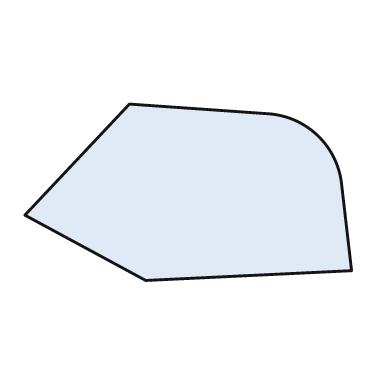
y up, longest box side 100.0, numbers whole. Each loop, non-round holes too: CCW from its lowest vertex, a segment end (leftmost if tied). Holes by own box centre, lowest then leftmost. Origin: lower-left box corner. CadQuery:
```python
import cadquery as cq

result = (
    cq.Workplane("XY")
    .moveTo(37.0, 0.0)
    .lineTo(100.0, 3.0)
    .lineTo(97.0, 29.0)
    .threePointArc((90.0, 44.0), (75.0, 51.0))
    .lineTo(32.0, 54.0)
    .lineTo(0.0, 20.0)
    .close()
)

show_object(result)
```